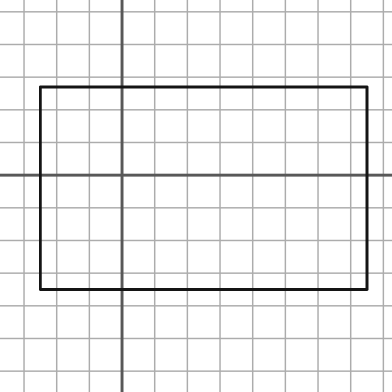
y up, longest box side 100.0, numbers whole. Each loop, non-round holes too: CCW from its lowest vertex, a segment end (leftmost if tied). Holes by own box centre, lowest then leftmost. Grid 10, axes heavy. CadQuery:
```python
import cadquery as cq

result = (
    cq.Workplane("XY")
    .moveTo(-25.0, -35.0)
    .lineTo(75.0, -35.0)
    .lineTo(75.0, 27.0)
    .lineTo(-25.0, 27.0)
    .close()
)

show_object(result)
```